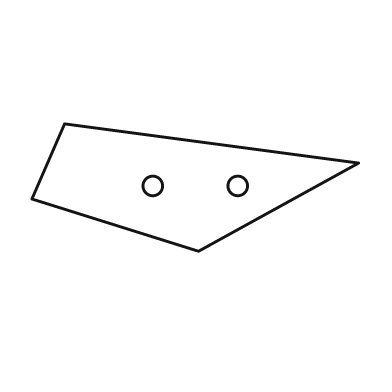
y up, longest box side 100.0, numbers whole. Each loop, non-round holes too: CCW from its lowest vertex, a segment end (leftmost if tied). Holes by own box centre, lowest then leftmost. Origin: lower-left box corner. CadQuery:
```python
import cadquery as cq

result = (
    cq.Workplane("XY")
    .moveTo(51.0, 0.0)
    .lineTo(100.0, 27.0)
    .lineTo(10.0, 39.0)
    .lineTo(0.0, 16.0)
    .close()
    .moveTo(37.0, 20.0)
    .circle(3.0)
    .moveTo(63.0, 20.0)
    .circle(3.0)
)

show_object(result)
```